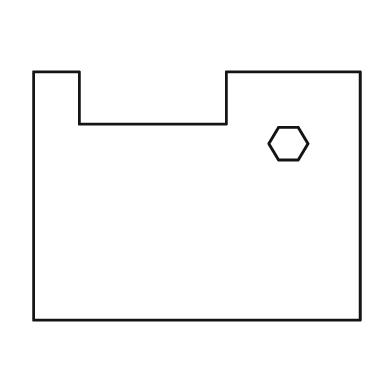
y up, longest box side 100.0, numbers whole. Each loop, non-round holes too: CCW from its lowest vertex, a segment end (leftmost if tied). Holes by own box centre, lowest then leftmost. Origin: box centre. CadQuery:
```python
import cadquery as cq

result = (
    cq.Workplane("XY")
    .moveTo(-50.0, -38.0)
    .lineTo(50.0, -38.0)
    .lineTo(50.0, 38.0)
    .lineTo(9.0, 38.0)
    .lineTo(9.0, 22.0)
    .lineTo(-36.0, 22.0)
    .lineTo(-36.0, 38.0)
    .lineTo(-50.0, 38.0)
    .close()
    .moveTo(25.0, 11.0)
    .lineTo(31.0, 11.0)
    .lineTo(34.0, 16.0)
    .lineTo(31.0, 21.0)
    .lineTo(25.0, 21.0)
    .lineTo(22.0, 16.0)
    .close()
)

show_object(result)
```